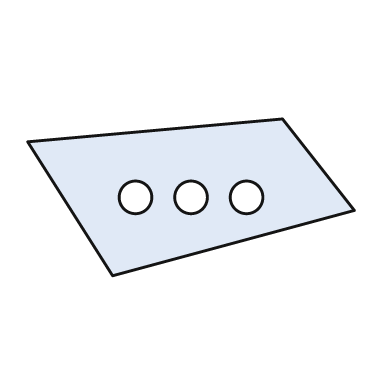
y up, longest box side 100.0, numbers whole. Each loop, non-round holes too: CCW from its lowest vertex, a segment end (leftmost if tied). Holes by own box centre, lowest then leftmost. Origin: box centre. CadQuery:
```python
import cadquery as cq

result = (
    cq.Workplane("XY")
    .moveTo(-24.0, -24.0)
    .lineTo(50.0, -4.0)
    .lineTo(28.0, 24.0)
    .lineTo(-50.0, 17.0)
    .close()
    .moveTo(-17.0, 0.0)
    .circle(5.0)
    .moveTo(0.0, 0.0)
    .circle(5.0)
    .moveTo(17.0, 0.0)
    .circle(5.0)
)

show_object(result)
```